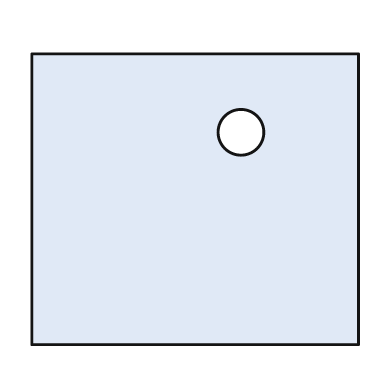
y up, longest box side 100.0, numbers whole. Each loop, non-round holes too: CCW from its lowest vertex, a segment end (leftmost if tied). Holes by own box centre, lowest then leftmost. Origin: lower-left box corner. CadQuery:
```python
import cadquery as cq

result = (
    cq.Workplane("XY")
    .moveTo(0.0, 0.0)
    .lineTo(100.0, 0.0)
    .lineTo(100.0, 89.0)
    .lineTo(0.0, 89.0)
    .close()
    .moveTo(64.0, 65.0)
    .circle(7.0)
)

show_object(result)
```